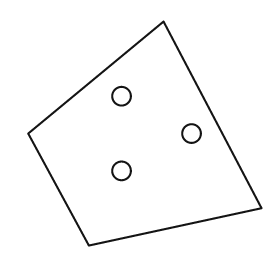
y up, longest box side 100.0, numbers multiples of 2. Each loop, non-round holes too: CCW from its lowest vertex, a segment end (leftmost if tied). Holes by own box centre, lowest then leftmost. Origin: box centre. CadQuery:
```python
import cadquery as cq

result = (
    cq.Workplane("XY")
    .moveTo(-24.0, -48.0)
    .lineTo(50.0, -32.0)
    .lineTo(8.0, 48.0)
    .lineTo(-50.0, 0.0)
    .close()
    .moveTo(-10.0, -16.0)
    .circle(4.0)
    .moveTo(20.0, 0.0)
    .circle(4.0)
    .moveTo(-10.0, 16.0)
    .circle(4.0)
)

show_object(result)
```